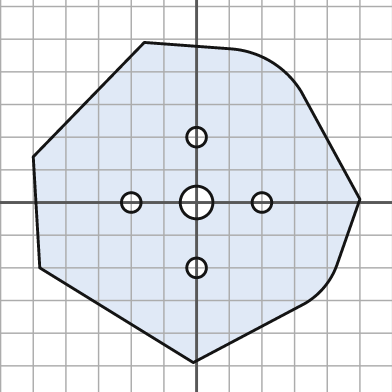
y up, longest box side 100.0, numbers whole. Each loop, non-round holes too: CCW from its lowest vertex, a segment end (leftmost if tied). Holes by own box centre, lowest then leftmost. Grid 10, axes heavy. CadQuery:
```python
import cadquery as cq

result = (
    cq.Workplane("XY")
    .moveTo(-1.0, -49.0)
    .lineTo(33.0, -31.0)
    .threePointArc((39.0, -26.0), (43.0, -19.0))
    .lineTo(50.0, 1.0)
    .lineTo(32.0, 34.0)
    .threePointArc((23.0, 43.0), (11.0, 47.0))
    .lineTo(-16.0, 49.0)
    .lineTo(-50.0, 14.0)
    .lineTo(-48.0, -20.0)
    .close()
    .moveTo(0.0, -20.0)
    .circle(3.0)
    .moveTo(-20.0, 0.0)
    .circle(3.0)
    .moveTo(0.0, 0.0)
    .circle(5.0)
    .moveTo(20.0, 0.0)
    .circle(3.0)
    .moveTo(0.0, 20.0)
    .circle(3.0)
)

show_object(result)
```